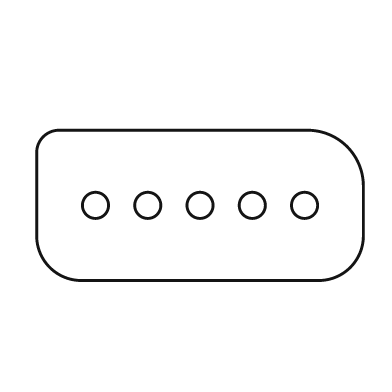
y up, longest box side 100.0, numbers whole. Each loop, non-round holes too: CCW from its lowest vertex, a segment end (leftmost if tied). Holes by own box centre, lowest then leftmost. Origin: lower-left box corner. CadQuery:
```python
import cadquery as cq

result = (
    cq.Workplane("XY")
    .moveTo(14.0, 0.0)
    .lineTo(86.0, 0.0)
    .threePointArc((96.0, 4.0), (100.0, 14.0))
    .lineTo(100.0, 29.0)
    .threePointArc((95.0, 41.0), (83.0, 46.0))
    .lineTo(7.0, 46.0)
    .threePointArc((2.0, 44.0), (0.0, 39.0))
    .lineTo(0.0, 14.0)
    .threePointArc((4.0, 4.0), (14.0, 0.0))
    .close()
    .moveTo(18.0, 23.0)
    .circle(4.0)
    .moveTo(34.0, 23.0)
    .circle(4.0)
    .moveTo(50.0, 23.0)
    .circle(4.0)
    .moveTo(66.0, 23.0)
    .circle(4.0)
    .moveTo(82.0, 23.0)
    .circle(4.0)
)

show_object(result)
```